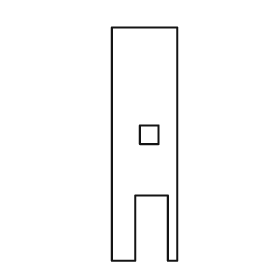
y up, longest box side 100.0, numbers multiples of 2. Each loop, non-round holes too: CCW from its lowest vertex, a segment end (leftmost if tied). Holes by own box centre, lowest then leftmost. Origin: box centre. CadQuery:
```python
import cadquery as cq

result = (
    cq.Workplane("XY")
    .moveTo(-14.0, -50.0)
    .lineTo(-4.0, -50.0)
    .lineTo(-4.0, -22.0)
    .lineTo(10.0, -22.0)
    .lineTo(10.0, -50.0)
    .lineTo(14.0, -50.0)
    .lineTo(14.0, 50.0)
    .lineTo(-14.0, 50.0)
    .close()
    .moveTo(-2.0, 0.0)
    .lineTo(6.0, 0.0)
    .lineTo(6.0, 8.0)
    .lineTo(-2.0, 8.0)
    .close()
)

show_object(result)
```